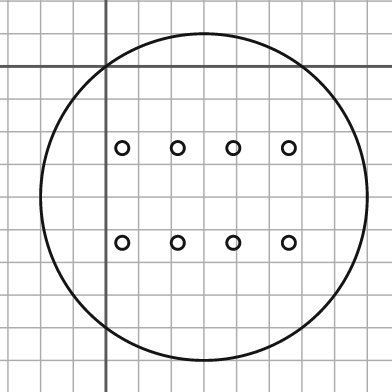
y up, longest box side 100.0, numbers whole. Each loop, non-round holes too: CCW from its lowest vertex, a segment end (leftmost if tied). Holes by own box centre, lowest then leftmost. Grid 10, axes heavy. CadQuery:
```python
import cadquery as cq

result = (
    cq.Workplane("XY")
    .moveTo(30.0, -40.0)
    .circle(50.0)
    .moveTo(5.0, -54.0)
    .circle(2.0)
    .moveTo(22.0, -54.0)
    .circle(2.0)
    .moveTo(39.0, -54.0)
    .circle(2.0)
    .moveTo(56.0, -54.0)
    .circle(2.0)
    .moveTo(5.0, -25.0)
    .circle(2.0)
    .moveTo(22.0, -25.0)
    .circle(2.0)
    .moveTo(39.0, -25.0)
    .circle(2.0)
    .moveTo(56.0, -25.0)
    .circle(2.0)
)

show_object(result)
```